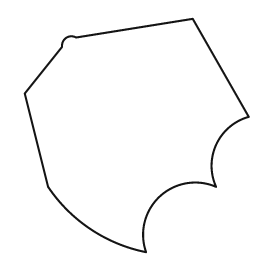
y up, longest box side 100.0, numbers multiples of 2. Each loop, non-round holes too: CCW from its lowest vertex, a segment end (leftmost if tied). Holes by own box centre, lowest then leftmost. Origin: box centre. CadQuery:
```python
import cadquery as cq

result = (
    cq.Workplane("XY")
    .moveTo(4.0, -50.0)
    .threePointArc((10.0, -26.0), (34.0, -22.0))
    .threePointArc((34.0, -4.0), (48.0, 8.0))
    .lineTo(24.0, 50.0)
    .lineTo(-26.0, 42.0)
    .threePointArc((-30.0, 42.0), (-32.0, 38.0))
    .lineTo(-48.0, 18.0)
    .lineTo(-38.0, -22.0)
    .threePointArc((-20.0, -40.0), (4.0, -50.0))
    .close()
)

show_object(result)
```